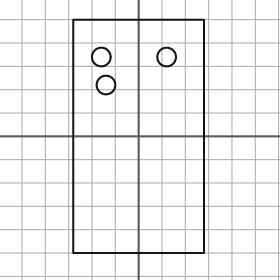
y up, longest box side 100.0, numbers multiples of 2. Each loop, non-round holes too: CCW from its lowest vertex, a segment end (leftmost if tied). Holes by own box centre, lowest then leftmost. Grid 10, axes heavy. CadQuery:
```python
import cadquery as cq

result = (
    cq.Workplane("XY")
    .moveTo(-28.0, -50.0)
    .lineTo(28.0, -50.0)
    .lineTo(28.0, 50.0)
    .lineTo(-28.0, 50.0)
    .close()
    .moveTo(-14.0, 22.0)
    .circle(4.0)
    .moveTo(-16.0, 34.0)
    .circle(4.0)
    .moveTo(12.0, 34.0)
    .circle(4.0)
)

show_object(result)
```